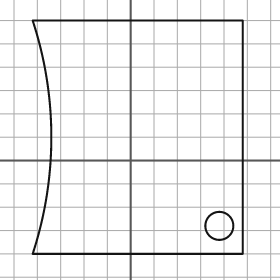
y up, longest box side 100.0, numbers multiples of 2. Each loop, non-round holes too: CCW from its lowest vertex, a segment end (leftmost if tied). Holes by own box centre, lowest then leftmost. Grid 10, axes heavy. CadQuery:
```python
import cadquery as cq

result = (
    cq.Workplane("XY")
    .moveTo(-42.0, -40.0)
    .lineTo(48.0, -40.0)
    .lineTo(48.0, 60.0)
    .lineTo(-42.0, 60.0)
    .threePointArc((-34.0, 10.0), (-42.0, -40.0))
    .close()
    .moveTo(38.0, -28.0)
    .circle(6.0)
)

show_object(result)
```